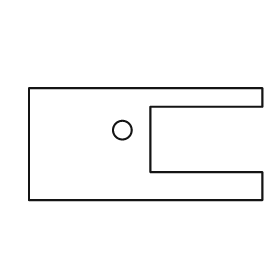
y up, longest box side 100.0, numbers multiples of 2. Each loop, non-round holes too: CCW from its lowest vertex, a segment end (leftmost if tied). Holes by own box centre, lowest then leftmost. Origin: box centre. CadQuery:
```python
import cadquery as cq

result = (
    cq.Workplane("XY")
    .moveTo(-50.0, -24.0)
    .lineTo(50.0, -24.0)
    .lineTo(50.0, -12.0)
    .lineTo(2.0, -12.0)
    .lineTo(2.0, 16.0)
    .lineTo(50.0, 16.0)
    .lineTo(50.0, 24.0)
    .lineTo(-50.0, 24.0)
    .close()
    .moveTo(-10.0, 6.0)
    .circle(4.0)
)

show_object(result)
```